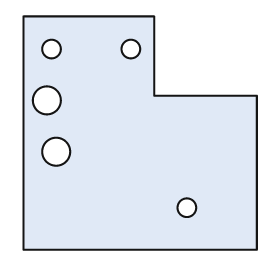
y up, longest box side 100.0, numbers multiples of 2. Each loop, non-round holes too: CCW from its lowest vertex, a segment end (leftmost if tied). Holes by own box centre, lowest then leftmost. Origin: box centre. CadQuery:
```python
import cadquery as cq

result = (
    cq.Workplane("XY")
    .moveTo(-50.0, -50.0)
    .lineTo(50.0, -50.0)
    .lineTo(50.0, 16.0)
    .lineTo(6.0, 16.0)
    .lineTo(6.0, 50.0)
    .lineTo(-50.0, 50.0)
    .close()
    .moveTo(20.0, -32.0)
    .circle(4.0)
    .moveTo(-36.0, -8.0)
    .circle(6.0)
    .moveTo(-40.0, 14.0)
    .circle(6.0)
    .moveTo(-38.0, 36.0)
    .circle(4.0)
    .moveTo(-4.0, 36.0)
    .circle(4.0)
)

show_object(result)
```